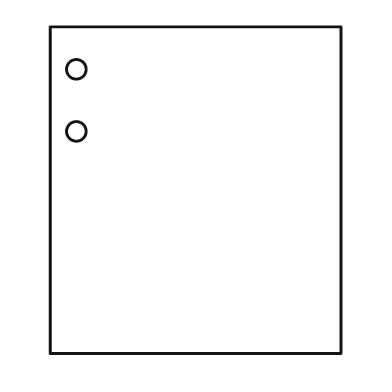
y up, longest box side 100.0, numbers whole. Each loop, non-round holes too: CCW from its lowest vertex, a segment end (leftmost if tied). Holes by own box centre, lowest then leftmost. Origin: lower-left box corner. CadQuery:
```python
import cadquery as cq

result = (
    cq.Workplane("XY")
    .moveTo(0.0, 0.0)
    .lineTo(89.0, 0.0)
    .lineTo(89.0, 100.0)
    .lineTo(0.0, 100.0)
    .close()
    .moveTo(8.0, 68.0)
    .circle(3.0)
    .moveTo(8.0, 87.0)
    .circle(3.0)
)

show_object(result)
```